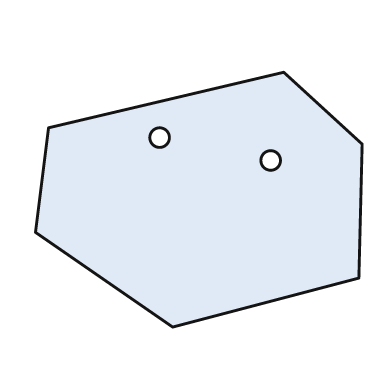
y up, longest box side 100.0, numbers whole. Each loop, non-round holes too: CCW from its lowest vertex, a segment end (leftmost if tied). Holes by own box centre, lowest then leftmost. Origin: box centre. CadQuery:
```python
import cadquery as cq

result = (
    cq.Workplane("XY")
    .moveTo(-8.0, -39.0)
    .lineTo(49.0, -24.0)
    .lineTo(50.0, 17.0)
    .lineTo(26.0, 39.0)
    .lineTo(-46.0, 22.0)
    .lineTo(-50.0, -10.0)
    .close()
    .moveTo(22.0, 12.0)
    .circle(3.0)
    .moveTo(-12.0, 19.0)
    .circle(3.0)
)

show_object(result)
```